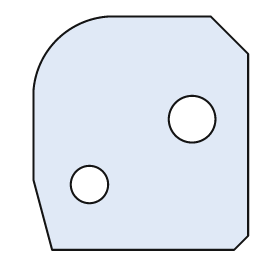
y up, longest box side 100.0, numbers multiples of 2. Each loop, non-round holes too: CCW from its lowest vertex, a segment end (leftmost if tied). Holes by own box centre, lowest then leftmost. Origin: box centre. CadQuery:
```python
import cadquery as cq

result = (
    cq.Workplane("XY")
    .moveTo(-38.0, -50.0)
    .lineTo(40.0, -50.0)
    .lineTo(46.0, -44.0)
    .lineTo(46.0, 34.0)
    .lineTo(30.0, 50.0)
    .lineTo(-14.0, 50.0)
    .threePointArc((-36.0, 40.0), (-46.0, 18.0))
    .lineTo(-46.0, -20.0)
    .close()
    .moveTo(-22.0, -22.0)
    .circle(8.0)
    .moveTo(22.0, 6.0)
    .circle(10.0)
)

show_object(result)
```